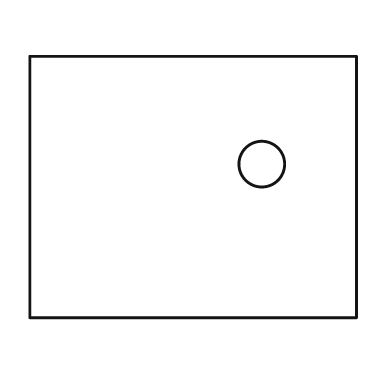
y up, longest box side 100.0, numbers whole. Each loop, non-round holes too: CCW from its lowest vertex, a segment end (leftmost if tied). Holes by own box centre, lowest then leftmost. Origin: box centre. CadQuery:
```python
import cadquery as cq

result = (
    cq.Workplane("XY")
    .moveTo(-50.0, -40.0)
    .lineTo(50.0, -40.0)
    .lineTo(50.0, 40.0)
    .lineTo(-50.0, 40.0)
    .close()
    .moveTo(21.0, 7.0)
    .circle(7.0)
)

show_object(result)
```